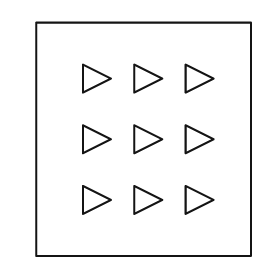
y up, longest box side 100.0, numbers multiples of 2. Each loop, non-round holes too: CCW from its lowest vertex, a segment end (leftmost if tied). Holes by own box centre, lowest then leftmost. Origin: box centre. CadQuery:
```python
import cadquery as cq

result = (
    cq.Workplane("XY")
    .moveTo(-46.0, -50.0)
    .lineTo(46.0, -50.0)
    .lineTo(46.0, 50.0)
    .lineTo(-46.0, 50.0)
    .close()
    .moveTo(-26.0, -32.0)
    .lineTo(-14.0, -26.0)
    .lineTo(-26.0, -20.0)
    .close()
    .moveTo(-4.0, -32.0)
    .lineTo(8.0, -26.0)
    .lineTo(-4.0, -20.0)
    .close()
    .moveTo(18.0, -32.0)
    .lineTo(30.0, -26.0)
    .lineTo(18.0, -20.0)
    .close()
    .moveTo(-26.0, -6.0)
    .lineTo(-14.0, 0.0)
    .lineTo(-26.0, 6.0)
    .close()
    .moveTo(-4.0, -6.0)
    .lineTo(8.0, 0.0)
    .lineTo(-4.0, 6.0)
    .close()
    .moveTo(18.0, -6.0)
    .lineTo(30.0, 0.0)
    .lineTo(18.0, 6.0)
    .close()
    .moveTo(-26.0, 20.0)
    .lineTo(-14.0, 26.0)
    .lineTo(-26.0, 32.0)
    .close()
    .moveTo(-4.0, 20.0)
    .lineTo(8.0, 26.0)
    .lineTo(-4.0, 32.0)
    .close()
    .moveTo(18.0, 20.0)
    .lineTo(30.0, 26.0)
    .lineTo(18.0, 32.0)
    .close()
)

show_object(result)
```